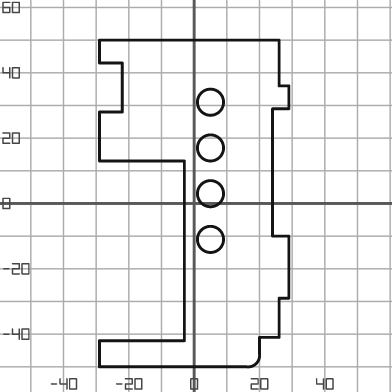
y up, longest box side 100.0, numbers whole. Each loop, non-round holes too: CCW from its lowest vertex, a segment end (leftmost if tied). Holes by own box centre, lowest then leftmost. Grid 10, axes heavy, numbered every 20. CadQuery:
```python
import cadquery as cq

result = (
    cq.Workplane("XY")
    .moveTo(-29.0, -50.0)
    .lineTo(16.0, -50.0)
    .threePointArc((19.0, -49.0), (20.0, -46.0))
    .lineTo(20.0, -41.0)
    .lineTo(26.0, -41.0)
    .lineTo(26.0, -29.0)
    .lineTo(29.0, -29.0)
    .lineTo(29.0, -10.0)
    .lineTo(24.0, -10.0)
    .lineTo(24.0, 29.0)
    .lineTo(29.0, 29.0)
    .lineTo(29.0, 36.0)
    .lineTo(26.0, 36.0)
    .lineTo(26.0, 50.0)
    .lineTo(-29.0, 50.0)
    .lineTo(-29.0, 43.0)
    .lineTo(-22.0, 43.0)
    .lineTo(-22.0, 28.0)
    .lineTo(-29.0, 28.0)
    .lineTo(-29.0, 13.0)
    .lineTo(-3.0, 13.0)
    .lineTo(-3.0, -42.0)
    .lineTo(-29.0, -42.0)
    .close()
    .moveTo(5.0, -11.0)
    .circle(4.0)
    .moveTo(5.0, 3.0)
    .circle(4.0)
    .moveTo(5.0, 17.0)
    .circle(4.0)
    .moveTo(5.0, 31.0)
    .circle(4.0)
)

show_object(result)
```